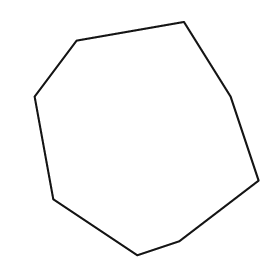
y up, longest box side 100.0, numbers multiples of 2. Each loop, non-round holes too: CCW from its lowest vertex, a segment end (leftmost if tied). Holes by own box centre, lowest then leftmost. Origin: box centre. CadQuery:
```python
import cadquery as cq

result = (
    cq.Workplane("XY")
    .moveTo(-4.0, -50.0)
    .lineTo(14.0, -44.0)
    .lineTo(48.0, -18.0)
    .lineTo(36.0, 18.0)
    .lineTo(16.0, 50.0)
    .lineTo(-30.0, 42.0)
    .lineTo(-48.0, 18.0)
    .lineTo(-40.0, -26.0)
    .close()
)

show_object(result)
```